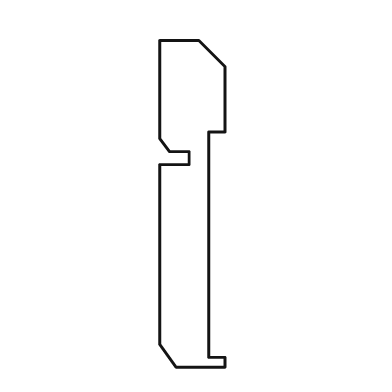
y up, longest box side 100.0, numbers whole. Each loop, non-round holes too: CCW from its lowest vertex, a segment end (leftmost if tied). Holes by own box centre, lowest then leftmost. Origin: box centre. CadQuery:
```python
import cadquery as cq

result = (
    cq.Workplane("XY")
    .moveTo(-5.0, -50.0)
    .lineTo(10.0, -50.0)
    .lineTo(10.0, -47.0)
    .lineTo(5.0, -47.0)
    .lineTo(5.0, 22.0)
    .lineTo(10.0, 22.0)
    .lineTo(10.0, 42.0)
    .lineTo(2.0, 50.0)
    .lineTo(-10.0, 50.0)
    .lineTo(-10.0, 20.0)
    .lineTo(-7.0, 16.0)
    .lineTo(-1.0, 16.0)
    .lineTo(-1.0, 12.0)
    .lineTo(-10.0, 12.0)
    .lineTo(-10.0, -43.0)
    .close()
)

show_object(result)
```